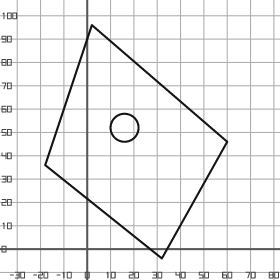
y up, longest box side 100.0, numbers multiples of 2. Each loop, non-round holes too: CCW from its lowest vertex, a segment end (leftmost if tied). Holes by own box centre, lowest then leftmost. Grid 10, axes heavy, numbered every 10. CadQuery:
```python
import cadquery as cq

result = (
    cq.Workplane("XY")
    .moveTo(32.0, -4.0)
    .lineTo(60.0, 46.0)
    .lineTo(2.0, 96.0)
    .lineTo(-18.0, 36.0)
    .close()
    .moveTo(16.0, 52.0)
    .circle(6.0)
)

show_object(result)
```